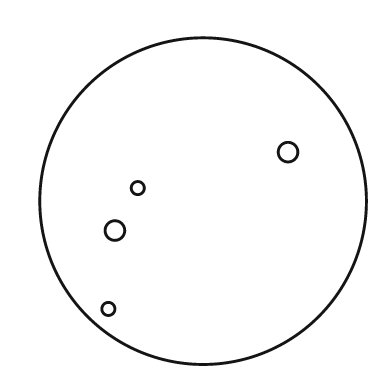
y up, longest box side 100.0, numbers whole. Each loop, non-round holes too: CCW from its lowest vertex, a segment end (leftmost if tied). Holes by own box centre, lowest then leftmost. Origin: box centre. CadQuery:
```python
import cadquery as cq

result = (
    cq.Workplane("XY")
    .moveTo(0.0, 0.0)
    .circle(50.0)
    .moveTo(-29.0, -33.0)
    .circle(2.0)
    .moveTo(-27.0, -9.0)
    .circle(3.0)
    .moveTo(-20.0, 4.0)
    .circle(2.0)
    .moveTo(26.0, 15.0)
    .circle(3.0)
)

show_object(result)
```